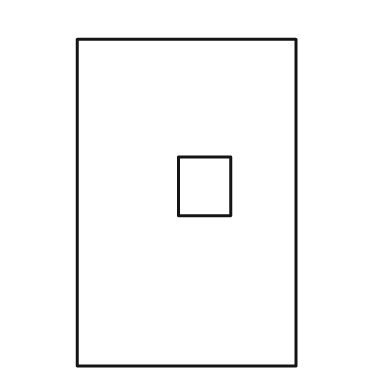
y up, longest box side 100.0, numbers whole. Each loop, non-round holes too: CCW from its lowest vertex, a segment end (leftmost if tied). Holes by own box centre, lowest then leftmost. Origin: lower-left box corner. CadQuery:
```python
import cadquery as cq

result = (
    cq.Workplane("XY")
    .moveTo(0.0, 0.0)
    .lineTo(67.0, 0.0)
    .lineTo(67.0, 100.0)
    .lineTo(0.0, 100.0)
    .close()
    .moveTo(31.0, 46.0)
    .lineTo(47.0, 46.0)
    .lineTo(47.0, 64.0)
    .lineTo(31.0, 64.0)
    .close()
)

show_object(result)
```